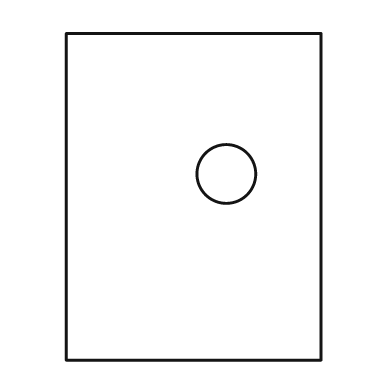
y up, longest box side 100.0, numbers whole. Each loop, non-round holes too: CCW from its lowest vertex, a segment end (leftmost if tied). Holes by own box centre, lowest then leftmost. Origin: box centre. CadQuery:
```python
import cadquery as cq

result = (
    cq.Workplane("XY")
    .moveTo(-39.0, -50.0)
    .lineTo(39.0, -50.0)
    .lineTo(39.0, 50.0)
    .lineTo(-39.0, 50.0)
    .close()
    .moveTo(10.0, 7.0)
    .circle(9.0)
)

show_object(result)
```